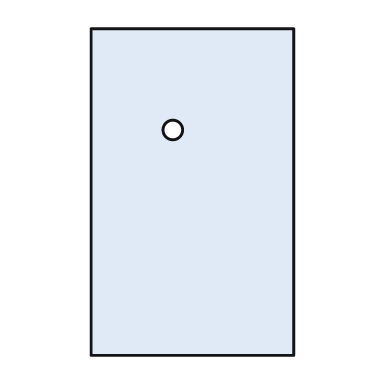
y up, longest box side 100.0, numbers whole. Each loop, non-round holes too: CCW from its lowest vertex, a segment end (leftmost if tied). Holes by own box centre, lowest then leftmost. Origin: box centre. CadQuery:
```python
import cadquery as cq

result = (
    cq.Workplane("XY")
    .moveTo(-31.0, -50.0)
    .lineTo(31.0, -50.0)
    .lineTo(31.0, 50.0)
    .lineTo(-31.0, 50.0)
    .close()
    .moveTo(-6.0, 19.0)
    .circle(3.0)
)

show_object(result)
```